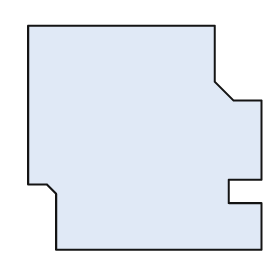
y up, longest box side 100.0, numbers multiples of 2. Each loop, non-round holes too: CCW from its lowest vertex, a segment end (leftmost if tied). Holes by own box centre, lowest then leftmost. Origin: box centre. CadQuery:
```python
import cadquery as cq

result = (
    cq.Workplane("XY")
    .moveTo(-38.0, -48.0)
    .lineTo(50.0, -48.0)
    .lineTo(50.0, -28.0)
    .lineTo(36.0, -28.0)
    .lineTo(36.0, -18.0)
    .lineTo(50.0, -18.0)
    .lineTo(50.0, 16.0)
    .lineTo(38.0, 16.0)
    .lineTo(30.0, 24.0)
    .lineTo(30.0, 48.0)
    .lineTo(-50.0, 48.0)
    .lineTo(-50.0, -20.0)
    .lineTo(-42.0, -20.0)
    .lineTo(-38.0, -24.0)
    .close()
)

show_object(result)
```